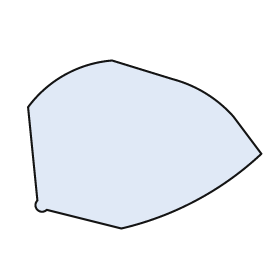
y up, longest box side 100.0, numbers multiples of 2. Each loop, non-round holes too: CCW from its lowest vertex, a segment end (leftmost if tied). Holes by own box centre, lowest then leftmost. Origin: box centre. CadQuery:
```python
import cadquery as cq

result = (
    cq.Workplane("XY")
    .moveTo(-10.0, -36.0)
    .threePointArc((22.0, -24.0), (50.0, -4.0))
    .lineTo(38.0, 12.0)
    .threePointArc((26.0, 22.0), (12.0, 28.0))
    .lineTo(-14.0, 36.0)
    .threePointArc((-34.0, 30.0), (-50.0, 16.0))
    .lineTo(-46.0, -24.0)
    .threePointArc((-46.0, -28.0), (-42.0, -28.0))
    .close()
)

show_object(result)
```